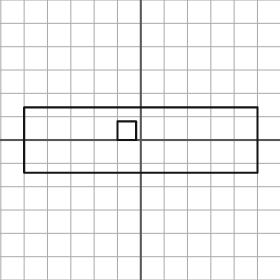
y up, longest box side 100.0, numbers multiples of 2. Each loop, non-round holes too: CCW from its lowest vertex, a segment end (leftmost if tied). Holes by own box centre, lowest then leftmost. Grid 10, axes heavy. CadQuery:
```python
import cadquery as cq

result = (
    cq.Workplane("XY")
    .moveTo(-50.0, -14.0)
    .lineTo(50.0, -14.0)
    .lineTo(50.0, 14.0)
    .lineTo(-50.0, 14.0)
    .close()
    .moveTo(-10.0, 0.0)
    .lineTo(-2.0, 0.0)
    .lineTo(-2.0, 8.0)
    .lineTo(-10.0, 8.0)
    .close()
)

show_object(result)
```